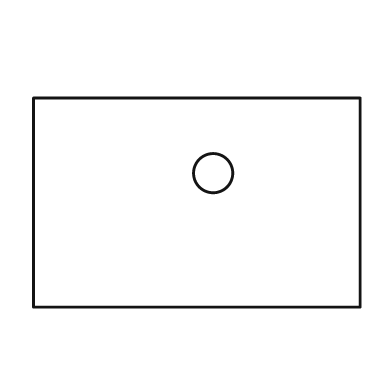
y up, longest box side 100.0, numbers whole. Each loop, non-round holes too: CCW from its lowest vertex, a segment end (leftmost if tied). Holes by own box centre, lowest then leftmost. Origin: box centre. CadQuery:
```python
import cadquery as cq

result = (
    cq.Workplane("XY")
    .moveTo(-50.0, -32.0)
    .lineTo(50.0, -32.0)
    .lineTo(50.0, 32.0)
    .lineTo(-50.0, 32.0)
    .close()
    .moveTo(5.0, 9.0)
    .circle(6.0)
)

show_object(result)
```